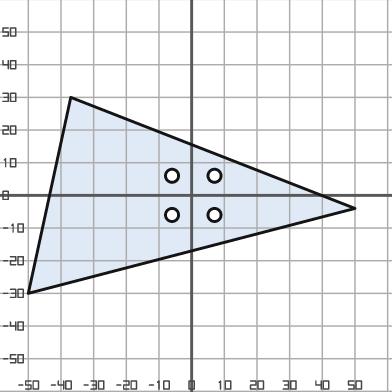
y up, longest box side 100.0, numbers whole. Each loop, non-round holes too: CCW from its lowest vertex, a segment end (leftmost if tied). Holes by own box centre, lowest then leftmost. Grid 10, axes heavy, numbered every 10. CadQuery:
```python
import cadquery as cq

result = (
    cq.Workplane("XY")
    .moveTo(-50.0, -30.0)
    .lineTo(50.0, -4.0)
    .lineTo(-37.0, 30.0)
    .close()
    .moveTo(-6.0, -6.0)
    .circle(2.0)
    .moveTo(7.0, -6.0)
    .circle(2.0)
    .moveTo(-6.0, 6.0)
    .circle(2.0)
    .moveTo(7.0, 6.0)
    .circle(2.0)
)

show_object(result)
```